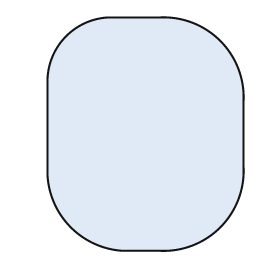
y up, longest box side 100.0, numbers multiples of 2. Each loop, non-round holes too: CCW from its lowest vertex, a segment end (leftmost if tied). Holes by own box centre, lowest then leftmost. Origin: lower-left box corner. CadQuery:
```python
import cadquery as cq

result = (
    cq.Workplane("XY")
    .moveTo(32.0, 0.0)
    .lineTo(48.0, 0.0)
    .threePointArc((74.0, 10.0), (84.0, 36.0))
    .lineTo(84.0, 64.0)
    .threePointArc((74.0, 90.0), (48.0, 100.0))
    .lineTo(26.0, 100.0)
    .threePointArc((8.0, 92.0), (0.0, 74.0))
    .lineTo(0.0, 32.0)
    .threePointArc((10.0, 10.0), (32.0, 0.0))
    .close()
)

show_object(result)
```